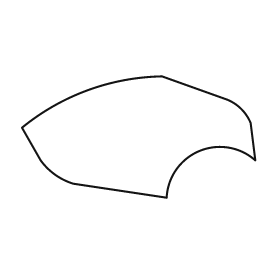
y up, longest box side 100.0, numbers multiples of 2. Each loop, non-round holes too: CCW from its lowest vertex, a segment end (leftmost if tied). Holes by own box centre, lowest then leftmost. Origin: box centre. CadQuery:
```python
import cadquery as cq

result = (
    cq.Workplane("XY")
    .moveTo(12.0, -26.0)
    .threePointArc((26.0, -6.0), (50.0, -10.0))
    .lineTo(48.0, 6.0)
    .threePointArc((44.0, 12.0), (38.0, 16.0))
    .lineTo(10.0, 26.0)
    .threePointArc((-22.0, 20.0), (-50.0, 4.0))
    .lineTo(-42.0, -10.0)
    .threePointArc((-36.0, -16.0), (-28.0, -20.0))
    .close()
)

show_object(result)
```